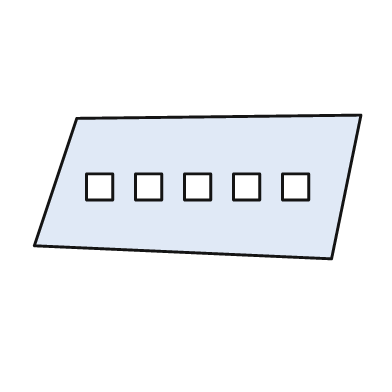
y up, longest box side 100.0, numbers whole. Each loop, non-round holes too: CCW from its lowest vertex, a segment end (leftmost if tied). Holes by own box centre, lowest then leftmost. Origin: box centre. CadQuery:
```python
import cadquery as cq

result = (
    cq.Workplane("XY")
    .moveTo(41.0, -22.0)
    .lineTo(50.0, 22.0)
    .lineTo(-37.0, 21.0)
    .lineTo(-50.0, -18.0)
    .close()
    .moveTo(-34.0, -4.0)
    .lineTo(-26.0, -4.0)
    .lineTo(-26.0, 4.0)
    .lineTo(-34.0, 4.0)
    .close()
    .moveTo(-19.0, -4.0)
    .lineTo(-11.0, -4.0)
    .lineTo(-11.0, 4.0)
    .lineTo(-19.0, 4.0)
    .close()
    .moveTo(-4.0, -4.0)
    .lineTo(4.0, -4.0)
    .lineTo(4.0, 4.0)
    .lineTo(-4.0, 4.0)
    .close()
    .moveTo(11.0, -4.0)
    .lineTo(19.0, -4.0)
    .lineTo(19.0, 4.0)
    .lineTo(11.0, 4.0)
    .close()
    .moveTo(26.0, -4.0)
    .lineTo(34.0, -4.0)
    .lineTo(34.0, 4.0)
    .lineTo(26.0, 4.0)
    .close()
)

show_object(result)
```